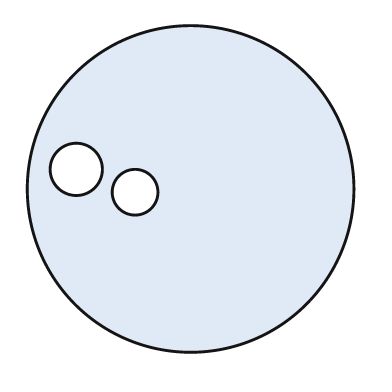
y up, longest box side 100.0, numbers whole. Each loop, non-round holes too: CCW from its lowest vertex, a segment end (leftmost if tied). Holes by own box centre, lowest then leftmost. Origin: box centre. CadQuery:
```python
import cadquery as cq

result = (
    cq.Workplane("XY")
    .moveTo(0.0, 0.0)
    .circle(50.0)
    .moveTo(-17.0, -1.0)
    .circle(7.0)
    .moveTo(-35.0, 6.0)
    .circle(8.0)
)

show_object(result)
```